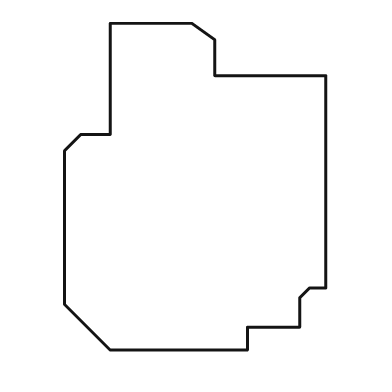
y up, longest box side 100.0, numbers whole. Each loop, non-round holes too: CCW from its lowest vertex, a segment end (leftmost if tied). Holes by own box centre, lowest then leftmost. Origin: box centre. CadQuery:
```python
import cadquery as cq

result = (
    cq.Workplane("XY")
    .moveTo(-26.0, -50.0)
    .lineTo(16.0, -50.0)
    .lineTo(16.0, -43.0)
    .lineTo(32.0, -43.0)
    .lineTo(32.0, -34.0)
    .lineTo(35.0, -31.0)
    .lineTo(40.0, -31.0)
    .lineTo(40.0, 34.0)
    .lineTo(6.0, 34.0)
    .lineTo(6.0, 45.0)
    .lineTo(-1.0, 50.0)
    .lineTo(-26.0, 50.0)
    .lineTo(-26.0, 16.0)
    .lineTo(-35.0, 16.0)
    .lineTo(-40.0, 11.0)
    .lineTo(-40.0, -36.0)
    .close()
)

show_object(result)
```